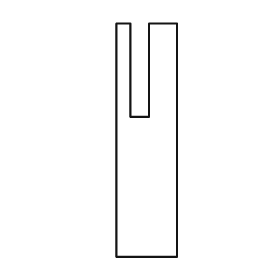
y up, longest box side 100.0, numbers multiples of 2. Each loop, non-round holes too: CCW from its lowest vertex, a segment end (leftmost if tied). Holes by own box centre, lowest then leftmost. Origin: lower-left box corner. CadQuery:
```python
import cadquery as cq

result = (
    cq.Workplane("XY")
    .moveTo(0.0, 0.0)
    .lineTo(26.0, 0.0)
    .lineTo(26.0, 100.0)
    .lineTo(14.0, 100.0)
    .lineTo(14.0, 60.0)
    .lineTo(6.0, 60.0)
    .lineTo(6.0, 100.0)
    .lineTo(0.0, 100.0)
    .close()
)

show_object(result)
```